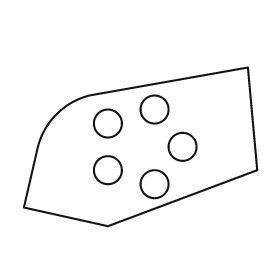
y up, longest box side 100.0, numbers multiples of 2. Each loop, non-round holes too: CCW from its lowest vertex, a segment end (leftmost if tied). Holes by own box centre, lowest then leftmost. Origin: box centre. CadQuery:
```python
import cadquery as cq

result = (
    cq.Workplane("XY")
    .moveTo(-14.0, -34.0)
    .lineTo(50.0, -10.0)
    .lineTo(46.0, 34.0)
    .lineTo(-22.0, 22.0)
    .threePointArc((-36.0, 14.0), (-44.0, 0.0))
    .lineTo(-50.0, -26.0)
    .close()
    .moveTo(6.0, -16.0)
    .circle(6.0)
    .moveTo(-14.0, -10.0)
    .circle(6.0)
    .moveTo(18.0, 0.0)
    .circle(6.0)
    .moveTo(-14.0, 10.0)
    .circle(6.0)
    .moveTo(6.0, 16.0)
    .circle(6.0)
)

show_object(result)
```